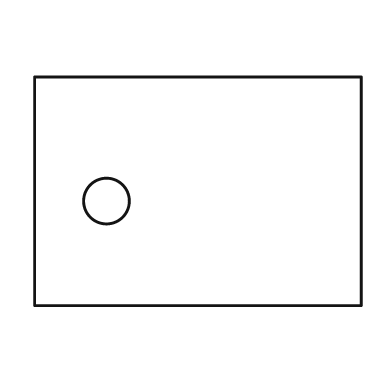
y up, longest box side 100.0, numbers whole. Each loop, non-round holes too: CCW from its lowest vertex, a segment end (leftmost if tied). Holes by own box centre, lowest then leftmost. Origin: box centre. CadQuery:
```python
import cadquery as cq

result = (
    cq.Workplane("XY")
    .moveTo(-50.0, -35.0)
    .lineTo(50.0, -35.0)
    .lineTo(50.0, 35.0)
    .lineTo(-50.0, 35.0)
    .close()
    .moveTo(-28.0, -3.0)
    .circle(7.0)
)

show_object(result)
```